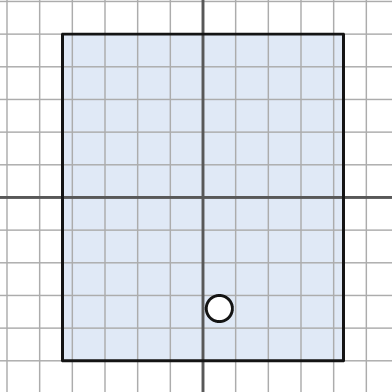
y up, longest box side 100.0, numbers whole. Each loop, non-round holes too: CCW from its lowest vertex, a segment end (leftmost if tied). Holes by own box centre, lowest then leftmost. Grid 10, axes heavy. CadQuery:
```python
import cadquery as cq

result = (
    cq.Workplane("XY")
    .moveTo(-43.0, -50.0)
    .lineTo(43.0, -50.0)
    .lineTo(43.0, 50.0)
    .lineTo(-43.0, 50.0)
    .close()
    .moveTo(5.0, -34.0)
    .circle(4.0)
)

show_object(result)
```